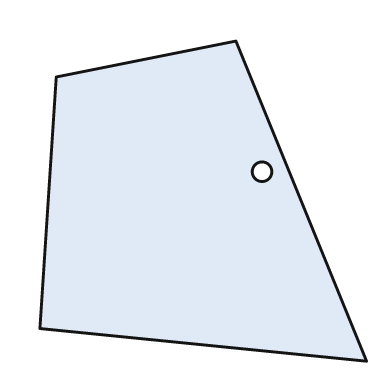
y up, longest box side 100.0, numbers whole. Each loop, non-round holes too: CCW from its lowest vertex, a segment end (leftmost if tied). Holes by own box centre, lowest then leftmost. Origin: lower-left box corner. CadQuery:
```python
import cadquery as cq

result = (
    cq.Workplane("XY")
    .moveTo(100.0, 0.0)
    .lineTo(60.0, 98.0)
    .lineTo(5.0, 87.0)
    .lineTo(0.0, 10.0)
    .close()
    .moveTo(68.0, 58.0)
    .circle(3.0)
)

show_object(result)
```